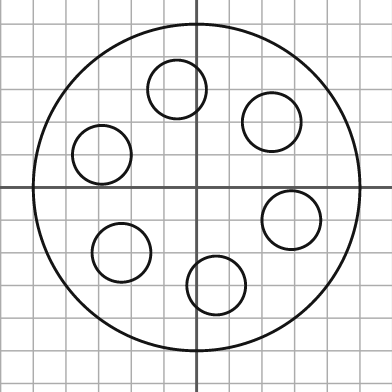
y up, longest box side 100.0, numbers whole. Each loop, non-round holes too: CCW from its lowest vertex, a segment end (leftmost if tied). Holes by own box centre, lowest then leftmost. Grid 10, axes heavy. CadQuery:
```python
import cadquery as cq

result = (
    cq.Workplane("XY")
    .moveTo(0.0, 0.0)
    .circle(50.0)
    .moveTo(6.0, -30.0)
    .circle(9.0)
    .moveTo(-23.0, -20.0)
    .circle(9.0)
    .moveTo(29.0, -10.0)
    .circle(9.0)
    .moveTo(-29.0, 10.0)
    .circle(9.0)
    .moveTo(23.0, 20.0)
    .circle(9.0)
    .moveTo(-6.0, 30.0)
    .circle(9.0)
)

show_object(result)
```